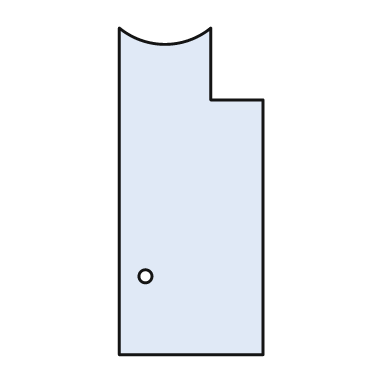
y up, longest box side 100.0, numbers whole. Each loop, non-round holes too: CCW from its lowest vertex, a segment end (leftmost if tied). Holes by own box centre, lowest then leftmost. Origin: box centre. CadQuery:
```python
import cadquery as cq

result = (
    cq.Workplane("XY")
    .moveTo(-22.0, -50.0)
    .lineTo(22.0, -50.0)
    .lineTo(22.0, 28.0)
    .lineTo(6.0, 28.0)
    .lineTo(6.0, 50.0)
    .threePointArc((-8.0, 45.0), (-22.0, 50.0))
    .close()
    .moveTo(-14.0, -26.0)
    .circle(2.0)
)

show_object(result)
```